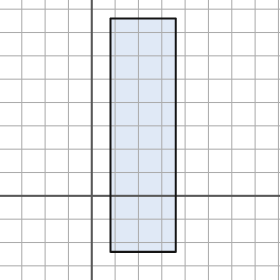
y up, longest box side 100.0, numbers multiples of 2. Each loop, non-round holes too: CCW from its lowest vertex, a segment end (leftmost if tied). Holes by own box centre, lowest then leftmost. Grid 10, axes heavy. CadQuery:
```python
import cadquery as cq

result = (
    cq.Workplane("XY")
    .moveTo(8.0, -24.0)
    .lineTo(36.0, -24.0)
    .lineTo(36.0, 76.0)
    .lineTo(8.0, 76.0)
    .close()
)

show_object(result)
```